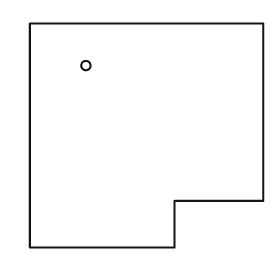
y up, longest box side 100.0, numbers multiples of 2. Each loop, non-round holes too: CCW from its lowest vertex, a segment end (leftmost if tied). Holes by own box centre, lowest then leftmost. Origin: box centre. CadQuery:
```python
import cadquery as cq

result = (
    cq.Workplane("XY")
    .moveTo(-50.0, -48.0)
    .lineTo(12.0, -48.0)
    .lineTo(12.0, -28.0)
    .lineTo(50.0, -28.0)
    .lineTo(50.0, 48.0)
    .lineTo(-50.0, 48.0)
    .close()
    .moveTo(-26.0, 30.0)
    .circle(2.0)
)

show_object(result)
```